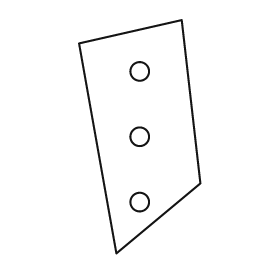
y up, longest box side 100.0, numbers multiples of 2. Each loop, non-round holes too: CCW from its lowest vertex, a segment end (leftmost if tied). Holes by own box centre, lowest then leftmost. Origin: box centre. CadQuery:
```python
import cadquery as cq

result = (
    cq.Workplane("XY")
    .moveTo(-10.0, -50.0)
    .lineTo(26.0, -20.0)
    .lineTo(18.0, 50.0)
    .lineTo(-26.0, 40.0)
    .close()
    .moveTo(0.0, -28.0)
    .circle(4.0)
    .moveTo(0.0, 0.0)
    .circle(4.0)
    .moveTo(0.0, 28.0)
    .circle(4.0)
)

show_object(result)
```